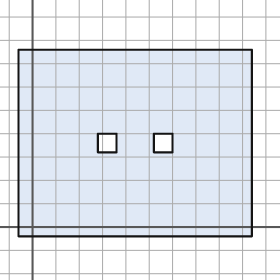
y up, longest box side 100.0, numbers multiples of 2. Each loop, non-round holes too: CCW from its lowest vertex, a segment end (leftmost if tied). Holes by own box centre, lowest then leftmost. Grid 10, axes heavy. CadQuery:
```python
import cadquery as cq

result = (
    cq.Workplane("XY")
    .moveTo(-6.0, -4.0)
    .lineTo(94.0, -4.0)
    .lineTo(94.0, 76.0)
    .lineTo(-6.0, 76.0)
    .close()
    .moveTo(28.0, 32.0)
    .lineTo(36.0, 32.0)
    .lineTo(36.0, 40.0)
    .lineTo(28.0, 40.0)
    .close()
    .moveTo(52.0, 32.0)
    .lineTo(60.0, 32.0)
    .lineTo(60.0, 40.0)
    .lineTo(52.0, 40.0)
    .close()
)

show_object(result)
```